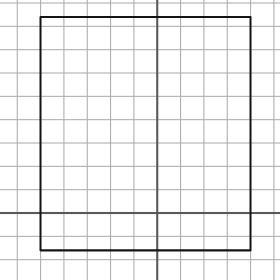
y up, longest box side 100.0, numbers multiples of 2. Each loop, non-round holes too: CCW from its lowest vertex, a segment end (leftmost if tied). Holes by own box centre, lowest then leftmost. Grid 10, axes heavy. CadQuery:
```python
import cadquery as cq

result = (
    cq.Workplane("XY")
    .moveTo(-50.0, -16.0)
    .lineTo(40.0, -16.0)
    .lineTo(40.0, 84.0)
    .lineTo(-50.0, 84.0)
    .close()
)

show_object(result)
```